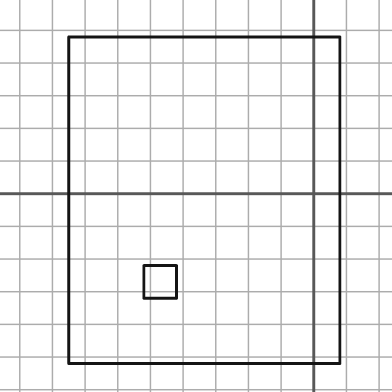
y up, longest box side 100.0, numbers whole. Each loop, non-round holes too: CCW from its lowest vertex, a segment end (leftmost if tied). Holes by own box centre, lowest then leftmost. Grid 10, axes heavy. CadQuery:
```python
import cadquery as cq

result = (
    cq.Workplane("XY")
    .moveTo(-75.0, -52.0)
    .lineTo(8.0, -52.0)
    .lineTo(8.0, 48.0)
    .lineTo(-75.0, 48.0)
    .close()
    .moveTo(-52.0, -32.0)
    .lineTo(-42.0, -32.0)
    .lineTo(-42.0, -22.0)
    .lineTo(-52.0, -22.0)
    .close()
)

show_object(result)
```